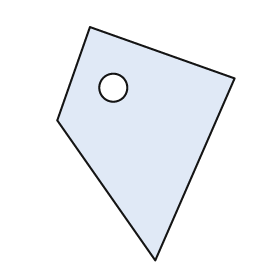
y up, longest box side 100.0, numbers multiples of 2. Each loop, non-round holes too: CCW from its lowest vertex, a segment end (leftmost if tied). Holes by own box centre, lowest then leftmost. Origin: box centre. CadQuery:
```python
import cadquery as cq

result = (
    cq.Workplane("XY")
    .moveTo(4.0, -50.0)
    .lineTo(38.0, 28.0)
    .lineTo(-24.0, 50.0)
    .lineTo(-38.0, 10.0)
    .close()
    .moveTo(-14.0, 24.0)
    .circle(6.0)
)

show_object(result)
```